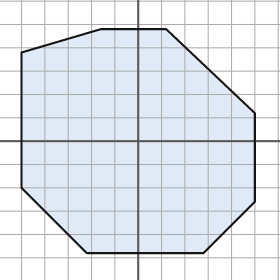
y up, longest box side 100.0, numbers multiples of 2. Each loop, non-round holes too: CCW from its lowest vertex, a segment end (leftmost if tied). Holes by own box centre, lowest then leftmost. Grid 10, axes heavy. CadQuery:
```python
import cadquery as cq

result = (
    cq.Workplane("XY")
    .moveTo(-22.0, -48.0)
    .lineTo(28.0, -48.0)
    .lineTo(50.0, -26.0)
    .lineTo(50.0, 12.0)
    .lineTo(12.0, 48.0)
    .lineTo(-16.0, 48.0)
    .lineTo(-50.0, 38.0)
    .lineTo(-50.0, -20.0)
    .close()
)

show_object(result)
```